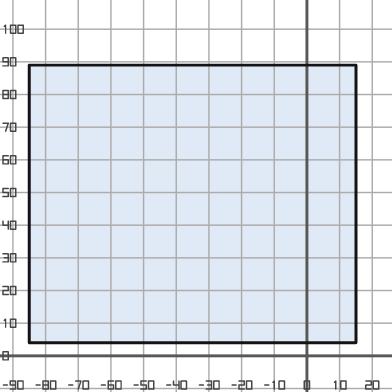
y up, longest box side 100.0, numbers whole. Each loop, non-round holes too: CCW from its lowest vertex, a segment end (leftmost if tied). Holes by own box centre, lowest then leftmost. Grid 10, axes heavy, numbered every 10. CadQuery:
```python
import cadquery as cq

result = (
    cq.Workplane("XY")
    .moveTo(-85.0, 4.0)
    .lineTo(15.0, 4.0)
    .lineTo(15.0, 89.0)
    .lineTo(-85.0, 89.0)
    .close()
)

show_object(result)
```